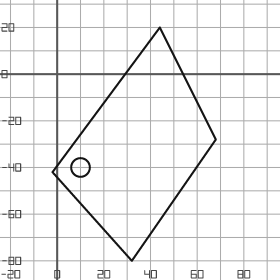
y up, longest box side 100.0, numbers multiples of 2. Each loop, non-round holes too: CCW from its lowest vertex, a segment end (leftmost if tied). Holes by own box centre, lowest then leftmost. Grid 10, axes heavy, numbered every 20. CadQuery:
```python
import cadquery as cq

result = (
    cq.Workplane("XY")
    .moveTo(32.0, -80.0)
    .lineTo(68.0, -28.0)
    .lineTo(44.0, 20.0)
    .lineTo(-2.0, -42.0)
    .close()
    .moveTo(10.0, -40.0)
    .circle(4.0)
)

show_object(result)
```